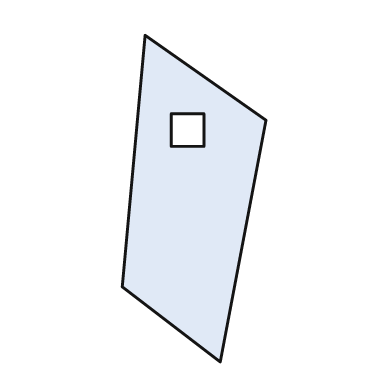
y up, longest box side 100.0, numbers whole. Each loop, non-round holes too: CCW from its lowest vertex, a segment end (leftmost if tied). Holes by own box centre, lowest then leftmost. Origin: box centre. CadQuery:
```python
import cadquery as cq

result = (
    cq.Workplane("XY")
    .moveTo(8.0, -50.0)
    .lineTo(22.0, 24.0)
    .lineTo(-15.0, 50.0)
    .lineTo(-22.0, -27.0)
    .close()
    .moveTo(-7.0, 16.0)
    .lineTo(3.0, 16.0)
    .lineTo(3.0, 26.0)
    .lineTo(-7.0, 26.0)
    .close()
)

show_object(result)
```